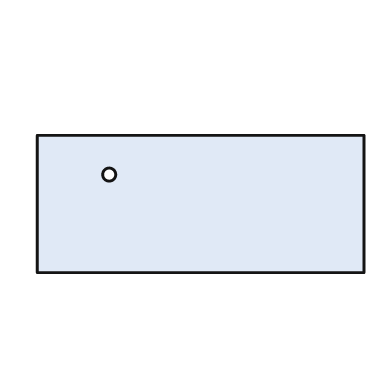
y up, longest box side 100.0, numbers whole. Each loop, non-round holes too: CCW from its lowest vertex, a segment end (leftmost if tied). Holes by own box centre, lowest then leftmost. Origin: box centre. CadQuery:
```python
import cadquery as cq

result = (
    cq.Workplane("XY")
    .moveTo(-50.0, -21.0)
    .lineTo(50.0, -21.0)
    .lineTo(50.0, 21.0)
    .lineTo(-50.0, 21.0)
    .close()
    .moveTo(-28.0, 9.0)
    .circle(2.0)
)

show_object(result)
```